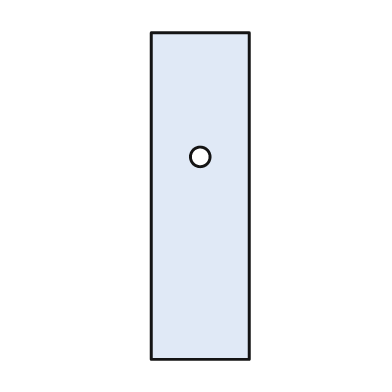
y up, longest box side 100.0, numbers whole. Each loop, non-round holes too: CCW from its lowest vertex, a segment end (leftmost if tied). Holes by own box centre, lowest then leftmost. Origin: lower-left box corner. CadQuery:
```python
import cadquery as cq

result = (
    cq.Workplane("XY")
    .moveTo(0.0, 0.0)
    .lineTo(30.0, 0.0)
    .lineTo(30.0, 100.0)
    .lineTo(0.0, 100.0)
    .close()
    .moveTo(15.0, 62.0)
    .circle(3.0)
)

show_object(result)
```